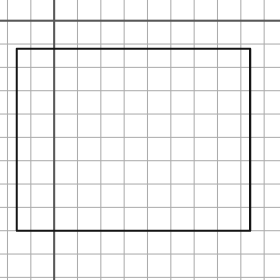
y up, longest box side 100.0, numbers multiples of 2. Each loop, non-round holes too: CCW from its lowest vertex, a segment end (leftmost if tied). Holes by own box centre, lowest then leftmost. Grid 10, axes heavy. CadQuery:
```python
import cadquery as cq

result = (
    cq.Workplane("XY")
    .moveTo(-16.0, -90.0)
    .lineTo(84.0, -90.0)
    .lineTo(84.0, -12.0)
    .lineTo(-16.0, -12.0)
    .close()
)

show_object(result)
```